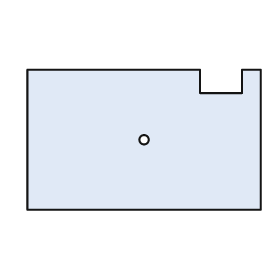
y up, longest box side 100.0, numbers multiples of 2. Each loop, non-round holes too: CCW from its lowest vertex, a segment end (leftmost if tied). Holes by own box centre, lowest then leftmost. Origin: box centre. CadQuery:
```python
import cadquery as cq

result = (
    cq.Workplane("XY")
    .moveTo(-50.0, -30.0)
    .lineTo(50.0, -30.0)
    .lineTo(50.0, 30.0)
    .lineTo(42.0, 30.0)
    .lineTo(42.0, 20.0)
    .lineTo(24.0, 20.0)
    .lineTo(24.0, 30.0)
    .lineTo(-50.0, 30.0)
    .close()
    .moveTo(0.0, 0.0)
    .circle(2.0)
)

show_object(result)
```